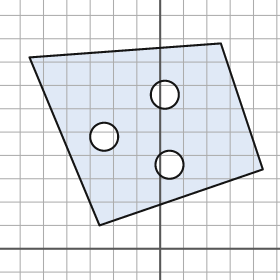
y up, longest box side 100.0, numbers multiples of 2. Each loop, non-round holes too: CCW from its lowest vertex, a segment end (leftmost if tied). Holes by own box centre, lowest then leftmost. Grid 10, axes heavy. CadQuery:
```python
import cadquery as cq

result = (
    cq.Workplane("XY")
    .moveTo(-26.0, 10.0)
    .lineTo(44.0, 34.0)
    .lineTo(26.0, 88.0)
    .lineTo(-56.0, 82.0)
    .close()
    .moveTo(4.0, 36.0)
    .circle(6.0)
    .moveTo(-24.0, 48.0)
    .circle(6.0)
    .moveTo(2.0, 66.0)
    .circle(6.0)
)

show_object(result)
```